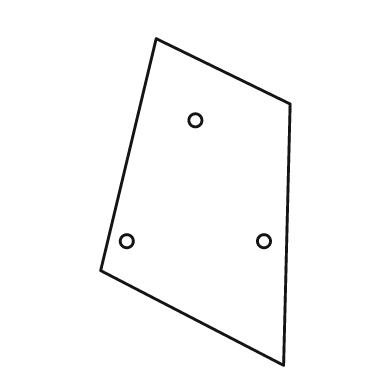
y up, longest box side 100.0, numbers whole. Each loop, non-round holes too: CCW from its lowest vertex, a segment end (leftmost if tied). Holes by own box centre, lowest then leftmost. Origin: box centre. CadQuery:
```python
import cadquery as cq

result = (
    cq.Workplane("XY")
    .moveTo(27.0, -50.0)
    .lineTo(29.0, 30.0)
    .lineTo(-12.0, 50.0)
    .lineTo(-29.0, -21.0)
    .close()
    .moveTo(-21.0, -12.0)
    .circle(2.0)
    .moveTo(21.0, -12.0)
    .circle(2.0)
    .moveTo(0.0, 25.0)
    .circle(2.0)
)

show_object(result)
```